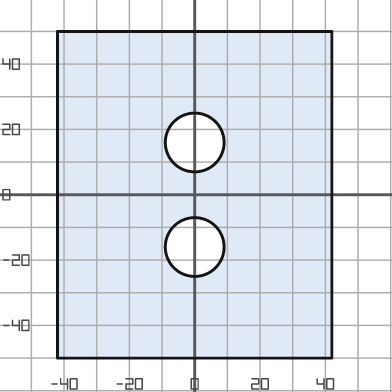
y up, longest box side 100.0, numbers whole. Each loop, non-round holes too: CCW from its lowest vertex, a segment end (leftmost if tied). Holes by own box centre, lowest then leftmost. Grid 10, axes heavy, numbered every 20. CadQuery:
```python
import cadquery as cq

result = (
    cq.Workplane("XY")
    .moveTo(-42.0, -50.0)
    .lineTo(42.0, -50.0)
    .lineTo(42.0, 50.0)
    .lineTo(-42.0, 50.0)
    .close()
    .moveTo(0.0, -16.0)
    .circle(9.0)
    .moveTo(0.0, 16.0)
    .circle(9.0)
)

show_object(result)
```